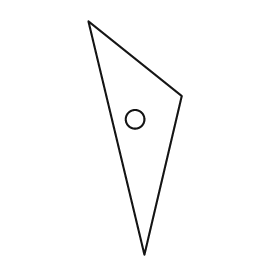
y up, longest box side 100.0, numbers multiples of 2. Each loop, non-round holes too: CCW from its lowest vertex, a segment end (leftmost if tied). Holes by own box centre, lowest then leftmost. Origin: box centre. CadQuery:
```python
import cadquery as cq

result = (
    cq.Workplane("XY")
    .moveTo(4.0, -50.0)
    .lineTo(20.0, 18.0)
    .lineTo(-20.0, 50.0)
    .close()
    .moveTo(0.0, 8.0)
    .circle(4.0)
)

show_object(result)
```